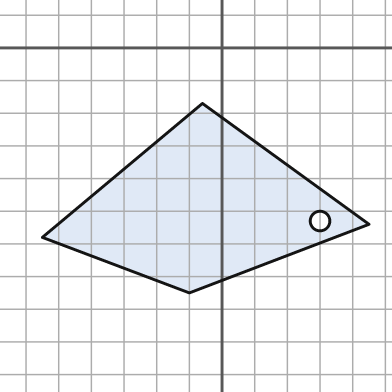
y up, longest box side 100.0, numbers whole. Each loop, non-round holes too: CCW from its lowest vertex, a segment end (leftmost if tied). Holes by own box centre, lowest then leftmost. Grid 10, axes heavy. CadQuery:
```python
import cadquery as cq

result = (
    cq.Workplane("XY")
    .moveTo(-10.0, -75.0)
    .lineTo(45.0, -54.0)
    .lineTo(-6.0, -17.0)
    .lineTo(-55.0, -58.0)
    .close()
    .moveTo(30.0, -53.0)
    .circle(3.0)
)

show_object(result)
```